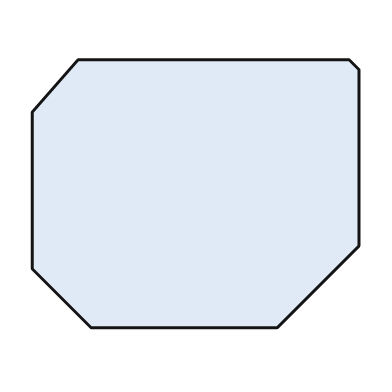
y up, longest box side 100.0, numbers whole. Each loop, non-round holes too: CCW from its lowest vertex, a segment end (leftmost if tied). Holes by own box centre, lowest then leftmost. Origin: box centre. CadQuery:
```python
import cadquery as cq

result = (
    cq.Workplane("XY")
    .moveTo(-32.0, -41.0)
    .lineTo(25.0, -41.0)
    .lineTo(50.0, -16.0)
    .lineTo(50.0, 38.0)
    .lineTo(47.0, 41.0)
    .lineTo(-36.0, 41.0)
    .lineTo(-50.0, 25.0)
    .lineTo(-50.0, -23.0)
    .close()
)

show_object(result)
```